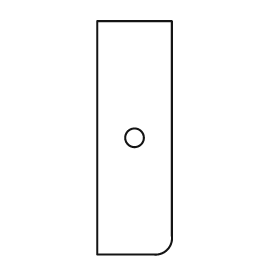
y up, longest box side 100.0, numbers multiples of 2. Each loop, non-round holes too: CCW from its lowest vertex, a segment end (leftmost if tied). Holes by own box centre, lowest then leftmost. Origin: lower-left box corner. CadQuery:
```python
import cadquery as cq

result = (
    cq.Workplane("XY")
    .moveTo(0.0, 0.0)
    .lineTo(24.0, 0.0)
    .threePointArc((30.0, 2.0), (32.0, 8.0))
    .lineTo(32.0, 100.0)
    .lineTo(0.0, 100.0)
    .close()
    .moveTo(16.0, 50.0)
    .circle(4.0)
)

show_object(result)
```